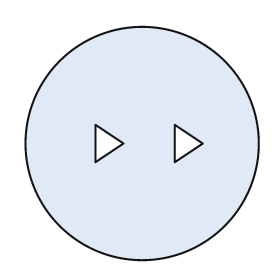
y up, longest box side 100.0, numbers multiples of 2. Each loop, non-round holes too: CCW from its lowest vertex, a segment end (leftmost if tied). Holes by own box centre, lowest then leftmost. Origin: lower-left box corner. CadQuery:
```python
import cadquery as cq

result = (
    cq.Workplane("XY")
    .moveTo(50.0, 50.0)
    .circle(50.0)
    .moveTo(30.0, 42.0)
    .lineTo(42.0, 50.0)
    .lineTo(30.0, 58.0)
    .close()
    .moveTo(64.0, 42.0)
    .lineTo(76.0, 50.0)
    .lineTo(64.0, 58.0)
    .close()
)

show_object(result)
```